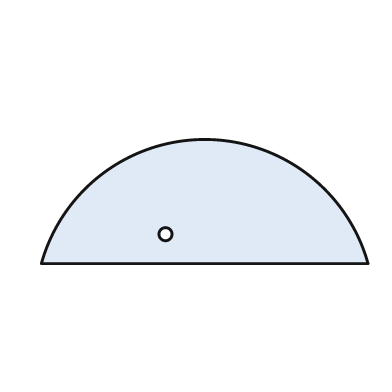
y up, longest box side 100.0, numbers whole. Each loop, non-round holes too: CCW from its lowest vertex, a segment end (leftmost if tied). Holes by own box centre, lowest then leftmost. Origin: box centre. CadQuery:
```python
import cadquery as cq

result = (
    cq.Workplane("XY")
    .moveTo(-50.0, -19.0)
    .lineTo(50.0, -19.0)
    .threePointArc((0.0, 19.0), (-50.0, -19.0))
    .close()
    .moveTo(-12.0, -10.0)
    .circle(2.0)
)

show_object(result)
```